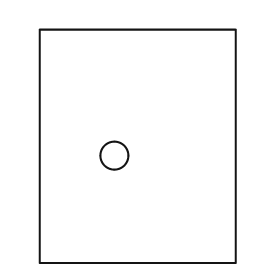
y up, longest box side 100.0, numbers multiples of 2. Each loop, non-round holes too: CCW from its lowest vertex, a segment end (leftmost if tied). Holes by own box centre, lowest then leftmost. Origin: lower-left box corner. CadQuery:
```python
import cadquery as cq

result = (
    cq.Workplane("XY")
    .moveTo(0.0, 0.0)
    .lineTo(84.0, 0.0)
    .lineTo(84.0, 100.0)
    .lineTo(0.0, 100.0)
    .close()
    .moveTo(32.0, 46.0)
    .circle(6.0)
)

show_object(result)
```